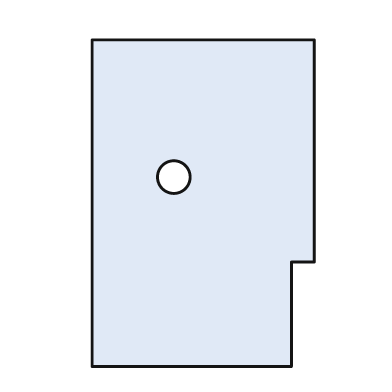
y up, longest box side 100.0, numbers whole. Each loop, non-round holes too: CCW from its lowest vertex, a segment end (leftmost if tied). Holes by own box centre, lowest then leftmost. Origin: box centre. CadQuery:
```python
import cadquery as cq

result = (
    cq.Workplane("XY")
    .moveTo(-34.0, -50.0)
    .lineTo(27.0, -50.0)
    .lineTo(27.0, -18.0)
    .lineTo(34.0, -18.0)
    .lineTo(34.0, 50.0)
    .lineTo(-34.0, 50.0)
    .close()
    .moveTo(-9.0, 8.0)
    .circle(5.0)
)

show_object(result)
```